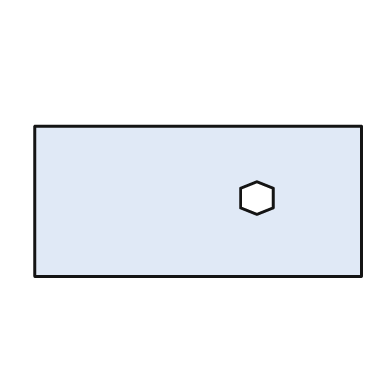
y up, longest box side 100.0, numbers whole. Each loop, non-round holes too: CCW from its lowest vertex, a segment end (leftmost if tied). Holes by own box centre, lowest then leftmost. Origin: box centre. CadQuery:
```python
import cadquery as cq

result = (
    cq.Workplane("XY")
    .moveTo(-50.0, -23.0)
    .lineTo(50.0, -23.0)
    .lineTo(50.0, 23.0)
    .lineTo(-50.0, 23.0)
    .close()
    .moveTo(18.0, -4.0)
    .lineTo(23.0, -2.0)
    .lineTo(23.0, 4.0)
    .lineTo(18.0, 6.0)
    .lineTo(13.0, 4.0)
    .lineTo(13.0, -2.0)
    .close()
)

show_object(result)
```